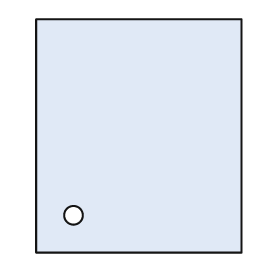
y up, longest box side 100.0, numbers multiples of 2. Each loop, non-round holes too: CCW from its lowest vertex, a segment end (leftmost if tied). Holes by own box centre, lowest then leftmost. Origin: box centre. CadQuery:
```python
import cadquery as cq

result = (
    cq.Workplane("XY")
    .moveTo(-44.0, -50.0)
    .lineTo(44.0, -50.0)
    .lineTo(44.0, 50.0)
    .lineTo(-44.0, 50.0)
    .close()
    .moveTo(-28.0, -34.0)
    .circle(4.0)
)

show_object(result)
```